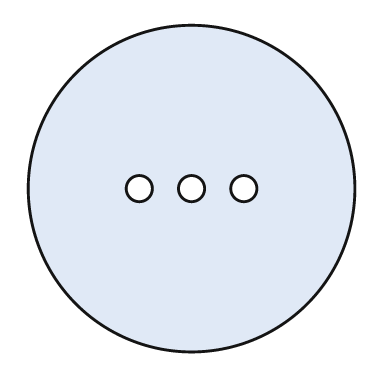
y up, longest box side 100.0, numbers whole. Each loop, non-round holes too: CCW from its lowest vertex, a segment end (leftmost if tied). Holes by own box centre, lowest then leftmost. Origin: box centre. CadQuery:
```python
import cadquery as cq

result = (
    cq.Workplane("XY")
    .moveTo(0.0, 0.0)
    .circle(50.0)
    .moveTo(-16.0, 0.0)
    .circle(4.0)
    .moveTo(0.0, 0.0)
    .circle(4.0)
    .moveTo(16.0, 0.0)
    .circle(4.0)
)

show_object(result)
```